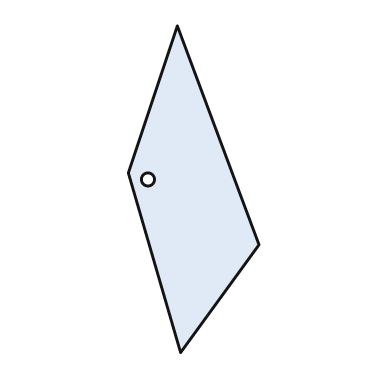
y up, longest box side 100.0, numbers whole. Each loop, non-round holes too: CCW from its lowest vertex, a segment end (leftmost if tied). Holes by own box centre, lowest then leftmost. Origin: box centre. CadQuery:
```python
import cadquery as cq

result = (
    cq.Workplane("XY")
    .moveTo(-4.0, -50.0)
    .lineTo(20.0, -17.0)
    .lineTo(-5.0, 50.0)
    .lineTo(-20.0, 5.0)
    .close()
    .moveTo(-14.0, 3.0)
    .circle(2.0)
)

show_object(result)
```